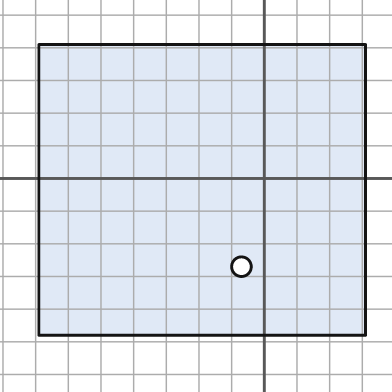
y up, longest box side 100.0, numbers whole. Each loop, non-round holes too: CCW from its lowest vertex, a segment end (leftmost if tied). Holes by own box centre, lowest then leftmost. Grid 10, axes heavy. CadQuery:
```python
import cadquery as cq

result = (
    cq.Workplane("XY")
    .moveTo(-69.0, -48.0)
    .lineTo(31.0, -48.0)
    .lineTo(31.0, 41.0)
    .lineTo(-69.0, 41.0)
    .close()
    .moveTo(-7.0, -27.0)
    .circle(3.0)
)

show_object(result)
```